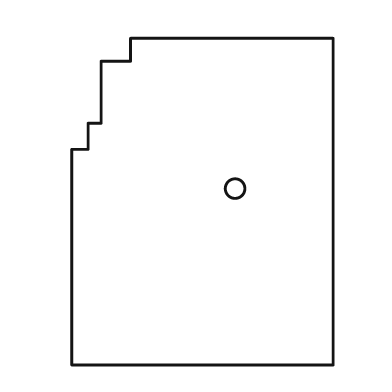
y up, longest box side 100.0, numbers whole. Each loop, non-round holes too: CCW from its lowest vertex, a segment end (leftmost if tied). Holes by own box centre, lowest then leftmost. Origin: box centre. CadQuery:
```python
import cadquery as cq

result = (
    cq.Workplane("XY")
    .moveTo(-40.0, -50.0)
    .lineTo(40.0, -50.0)
    .lineTo(40.0, 50.0)
    .lineTo(-22.0, 50.0)
    .lineTo(-22.0, 43.0)
    .lineTo(-31.0, 43.0)
    .lineTo(-31.0, 24.0)
    .lineTo(-35.0, 24.0)
    .lineTo(-35.0, 16.0)
    .lineTo(-40.0, 16.0)
    .close()
    .moveTo(10.0, 4.0)
    .circle(3.0)
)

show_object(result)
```